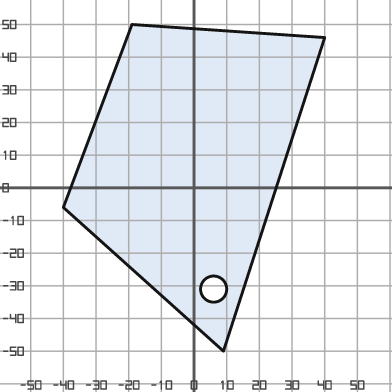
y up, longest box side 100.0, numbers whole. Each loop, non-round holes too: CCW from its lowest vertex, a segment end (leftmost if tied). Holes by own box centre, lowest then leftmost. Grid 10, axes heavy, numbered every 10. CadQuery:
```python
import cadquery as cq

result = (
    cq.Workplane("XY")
    .moveTo(9.0, -50.0)
    .lineTo(40.0, 46.0)
    .lineTo(-19.0, 50.0)
    .lineTo(-40.0, -6.0)
    .close()
    .moveTo(6.0, -31.0)
    .circle(4.0)
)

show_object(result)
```